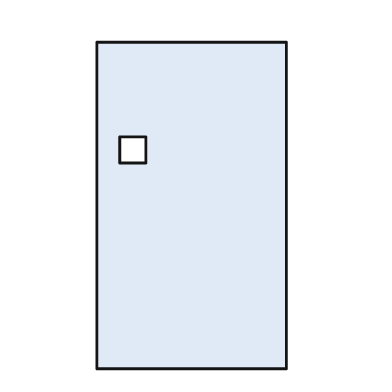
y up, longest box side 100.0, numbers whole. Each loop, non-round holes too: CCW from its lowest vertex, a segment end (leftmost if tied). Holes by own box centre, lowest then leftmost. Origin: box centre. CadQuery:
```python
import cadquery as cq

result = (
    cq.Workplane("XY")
    .moveTo(-29.0, -50.0)
    .lineTo(29.0, -50.0)
    .lineTo(29.0, 50.0)
    .lineTo(-29.0, 50.0)
    .close()
    .moveTo(-22.0, 13.0)
    .lineTo(-14.0, 13.0)
    .lineTo(-14.0, 21.0)
    .lineTo(-22.0, 21.0)
    .close()
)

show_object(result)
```